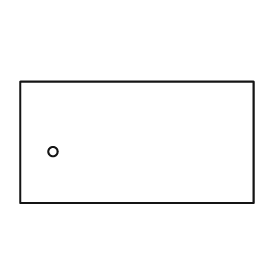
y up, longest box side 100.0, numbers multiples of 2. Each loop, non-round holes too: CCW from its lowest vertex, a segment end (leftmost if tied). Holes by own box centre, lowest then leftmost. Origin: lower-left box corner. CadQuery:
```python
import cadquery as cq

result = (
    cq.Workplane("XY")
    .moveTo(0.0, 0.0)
    .lineTo(100.0, 0.0)
    .lineTo(100.0, 52.0)
    .lineTo(0.0, 52.0)
    .close()
    .moveTo(14.0, 22.0)
    .circle(2.0)
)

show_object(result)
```